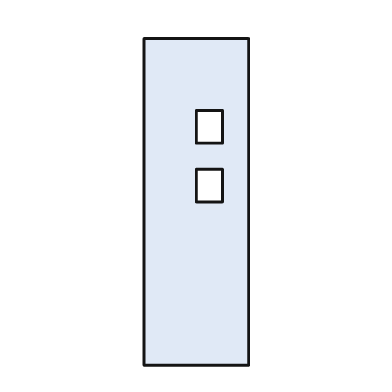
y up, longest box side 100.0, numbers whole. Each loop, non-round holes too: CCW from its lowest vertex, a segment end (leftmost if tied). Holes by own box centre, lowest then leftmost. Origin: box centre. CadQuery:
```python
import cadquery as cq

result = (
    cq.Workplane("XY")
    .moveTo(-16.0, -50.0)
    .lineTo(16.0, -50.0)
    .lineTo(16.0, 50.0)
    .lineTo(-16.0, 50.0)
    .close()
    .moveTo(0.0, 0.0)
    .lineTo(8.0, 0.0)
    .lineTo(8.0, 10.0)
    .lineTo(0.0, 10.0)
    .close()
    .moveTo(0.0, 18.0)
    .lineTo(8.0, 18.0)
    .lineTo(8.0, 28.0)
    .lineTo(0.0, 28.0)
    .close()
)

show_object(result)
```